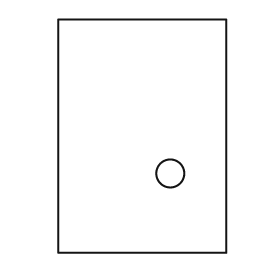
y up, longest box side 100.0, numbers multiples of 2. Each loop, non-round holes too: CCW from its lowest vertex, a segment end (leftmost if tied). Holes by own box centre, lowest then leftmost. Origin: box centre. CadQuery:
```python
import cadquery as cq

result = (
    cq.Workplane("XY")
    .moveTo(-36.0, -50.0)
    .lineTo(36.0, -50.0)
    .lineTo(36.0, 50.0)
    .lineTo(-36.0, 50.0)
    .close()
    .moveTo(12.0, -16.0)
    .circle(6.0)
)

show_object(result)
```